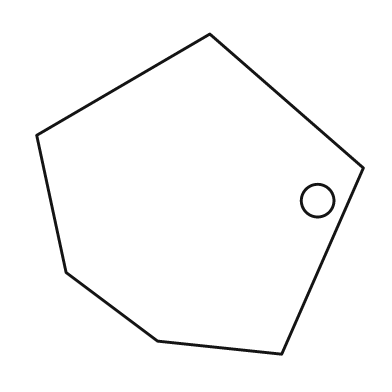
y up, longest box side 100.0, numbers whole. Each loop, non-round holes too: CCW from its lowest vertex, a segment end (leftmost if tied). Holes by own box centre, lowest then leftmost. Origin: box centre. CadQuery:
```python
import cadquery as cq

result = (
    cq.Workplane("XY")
    .moveTo(25.0, -49.0)
    .lineTo(50.0, 8.0)
    .lineTo(3.0, 49.0)
    .lineTo(-50.0, 18.0)
    .lineTo(-41.0, -24.0)
    .lineTo(-13.0, -45.0)
    .close()
    .moveTo(36.0, -2.0)
    .circle(5.0)
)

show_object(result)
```